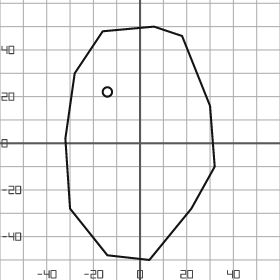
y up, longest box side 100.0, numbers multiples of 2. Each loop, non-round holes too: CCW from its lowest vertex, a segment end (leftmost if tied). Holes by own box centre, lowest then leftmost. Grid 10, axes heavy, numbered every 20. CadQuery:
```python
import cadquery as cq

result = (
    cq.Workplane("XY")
    .moveTo(4.0, -50.0)
    .lineTo(22.0, -28.0)
    .lineTo(32.0, -10.0)
    .lineTo(30.0, 16.0)
    .lineTo(18.0, 46.0)
    .lineTo(6.0, 50.0)
    .lineTo(-16.0, 48.0)
    .lineTo(-28.0, 30.0)
    .lineTo(-32.0, 2.0)
    .lineTo(-30.0, -28.0)
    .lineTo(-14.0, -48.0)
    .close()
    .moveTo(-14.0, 22.0)
    .circle(2.0)
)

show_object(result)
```